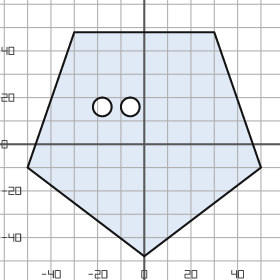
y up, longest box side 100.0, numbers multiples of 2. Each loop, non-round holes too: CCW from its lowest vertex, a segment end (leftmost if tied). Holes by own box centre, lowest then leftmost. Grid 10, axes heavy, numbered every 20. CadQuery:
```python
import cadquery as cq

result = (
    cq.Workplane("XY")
    .moveTo(0.0, -48.0)
    .lineTo(50.0, -10.0)
    .lineTo(30.0, 48.0)
    .lineTo(-30.0, 48.0)
    .lineTo(-50.0, -10.0)
    .close()
    .moveTo(-18.0, 16.0)
    .circle(4.0)
    .moveTo(-6.0, 16.0)
    .circle(4.0)
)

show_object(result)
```